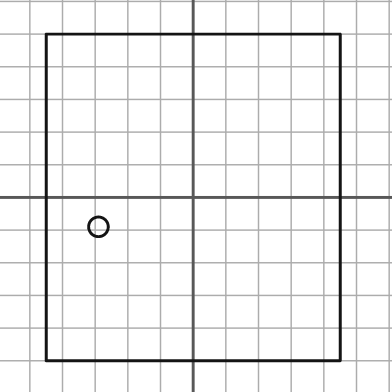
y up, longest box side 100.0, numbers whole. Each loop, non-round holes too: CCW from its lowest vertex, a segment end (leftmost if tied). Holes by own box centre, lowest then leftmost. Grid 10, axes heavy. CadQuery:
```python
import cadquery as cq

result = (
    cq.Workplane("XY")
    .moveTo(-45.0, -50.0)
    .lineTo(45.0, -50.0)
    .lineTo(45.0, 50.0)
    .lineTo(-45.0, 50.0)
    .close()
    .moveTo(-29.0, -9.0)
    .circle(3.0)
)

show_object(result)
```